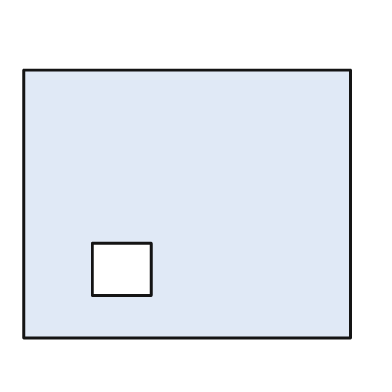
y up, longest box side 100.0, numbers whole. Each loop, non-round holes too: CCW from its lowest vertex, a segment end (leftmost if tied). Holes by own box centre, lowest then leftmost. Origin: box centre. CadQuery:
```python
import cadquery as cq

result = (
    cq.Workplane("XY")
    .moveTo(-50.0, -41.0)
    .lineTo(50.0, -41.0)
    .lineTo(50.0, 41.0)
    .lineTo(-50.0, 41.0)
    .close()
    .moveTo(-29.0, -28.0)
    .lineTo(-11.0, -28.0)
    .lineTo(-11.0, -12.0)
    .lineTo(-29.0, -12.0)
    .close()
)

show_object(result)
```